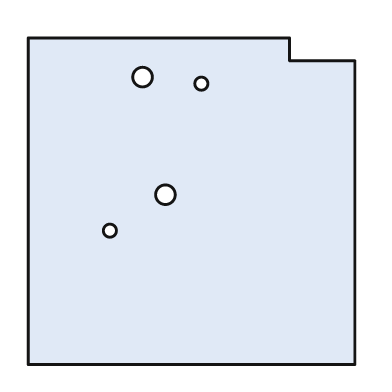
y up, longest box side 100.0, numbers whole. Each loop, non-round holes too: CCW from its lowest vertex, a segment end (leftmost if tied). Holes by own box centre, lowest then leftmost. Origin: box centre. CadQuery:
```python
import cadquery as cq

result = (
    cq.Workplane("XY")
    .moveTo(-50.0, -50.0)
    .lineTo(50.0, -50.0)
    .lineTo(50.0, 43.0)
    .lineTo(30.0, 43.0)
    .lineTo(30.0, 50.0)
    .lineTo(-50.0, 50.0)
    .close()
    .moveTo(-25.0, -9.0)
    .circle(2.0)
    .moveTo(-8.0, 2.0)
    .circle(3.0)
    .moveTo(3.0, 36.0)
    .circle(2.0)
    .moveTo(-15.0, 38.0)
    .circle(3.0)
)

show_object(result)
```